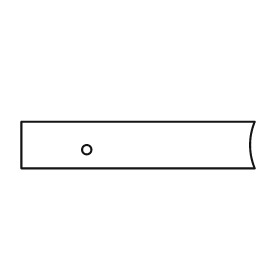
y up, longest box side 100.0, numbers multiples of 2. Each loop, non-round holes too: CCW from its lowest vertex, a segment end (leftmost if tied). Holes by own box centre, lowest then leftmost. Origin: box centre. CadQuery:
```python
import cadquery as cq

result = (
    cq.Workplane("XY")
    .moveTo(-50.0, -10.0)
    .lineTo(50.0, -10.0)
    .threePointArc((48.0, 0.0), (50.0, 10.0))
    .lineTo(-50.0, 10.0)
    .close()
    .moveTo(-22.0, -2.0)
    .circle(2.0)
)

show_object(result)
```